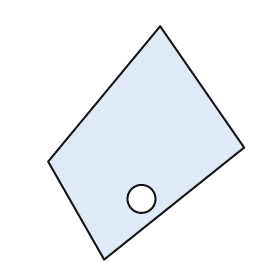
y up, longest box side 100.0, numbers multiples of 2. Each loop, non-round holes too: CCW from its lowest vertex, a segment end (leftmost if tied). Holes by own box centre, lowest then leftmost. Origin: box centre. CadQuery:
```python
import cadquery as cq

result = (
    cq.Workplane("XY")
    .moveTo(-18.0, -50.0)
    .lineTo(42.0, -2.0)
    .lineTo(6.0, 50.0)
    .lineTo(-42.0, -8.0)
    .close()
    .moveTo(-2.0, -24.0)
    .circle(6.0)
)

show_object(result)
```